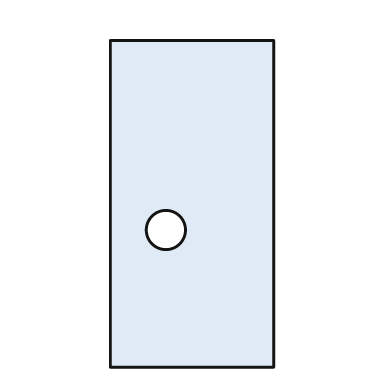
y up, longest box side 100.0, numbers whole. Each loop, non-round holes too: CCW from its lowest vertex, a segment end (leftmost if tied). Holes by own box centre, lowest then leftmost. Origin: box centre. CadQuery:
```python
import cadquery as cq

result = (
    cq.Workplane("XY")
    .moveTo(-25.0, -50.0)
    .lineTo(25.0, -50.0)
    .lineTo(25.0, 50.0)
    .lineTo(-25.0, 50.0)
    .close()
    .moveTo(-8.0, -8.0)
    .circle(6.0)
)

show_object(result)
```